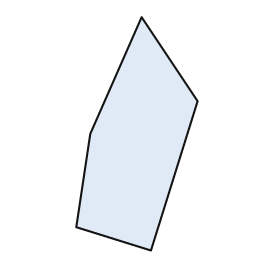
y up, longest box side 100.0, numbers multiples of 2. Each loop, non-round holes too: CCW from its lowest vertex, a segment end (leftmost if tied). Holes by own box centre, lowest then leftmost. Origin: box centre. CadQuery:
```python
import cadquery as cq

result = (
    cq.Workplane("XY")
    .moveTo(6.0, -50.0)
    .lineTo(26.0, 14.0)
    .lineTo(2.0, 50.0)
    .lineTo(-20.0, 0.0)
    .lineTo(-26.0, -40.0)
    .close()
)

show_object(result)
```